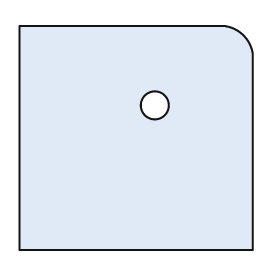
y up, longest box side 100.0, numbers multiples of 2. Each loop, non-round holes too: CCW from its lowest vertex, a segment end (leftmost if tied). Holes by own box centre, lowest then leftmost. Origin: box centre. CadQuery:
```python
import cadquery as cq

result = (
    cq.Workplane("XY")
    .moveTo(-50.0, -48.0)
    .lineTo(50.0, -48.0)
    .lineTo(50.0, 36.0)
    .threePointArc((46.0, 44.0), (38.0, 48.0))
    .lineTo(-50.0, 48.0)
    .close()
    .moveTo(8.0, 14.0)
    .circle(6.0)
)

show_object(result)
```